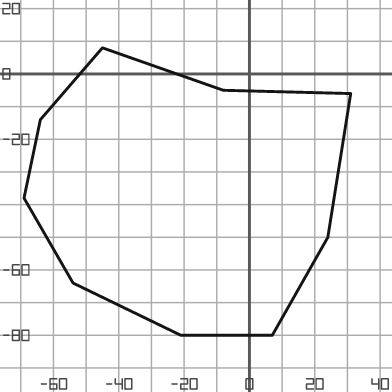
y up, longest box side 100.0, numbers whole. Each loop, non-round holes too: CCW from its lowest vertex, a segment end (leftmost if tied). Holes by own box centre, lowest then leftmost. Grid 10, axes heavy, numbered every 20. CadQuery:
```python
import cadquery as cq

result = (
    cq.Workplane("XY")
    .moveTo(-21.0, -80.0)
    .lineTo(7.0, -80.0)
    .lineTo(24.0, -50.0)
    .lineTo(31.0, -6.0)
    .lineTo(-8.0, -5.0)
    .lineTo(-45.0, 8.0)
    .lineTo(-64.0, -14.0)
    .lineTo(-69.0, -38.0)
    .lineTo(-54.0, -64.0)
    .close()
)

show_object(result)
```